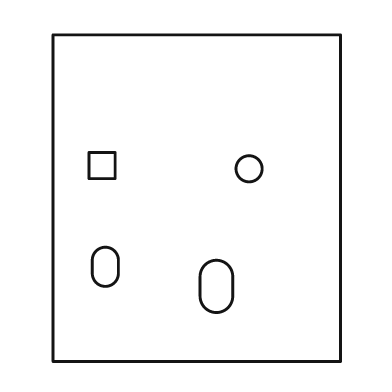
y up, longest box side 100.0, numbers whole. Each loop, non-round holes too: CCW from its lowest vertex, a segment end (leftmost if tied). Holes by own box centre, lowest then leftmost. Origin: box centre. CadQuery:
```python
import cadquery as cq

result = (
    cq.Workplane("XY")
    .moveTo(-44.0, -50.0)
    .lineTo(44.0, -50.0)
    .lineTo(44.0, 50.0)
    .lineTo(-44.0, 50.0)
    .close()
    .moveTo(1.0, -30.0)
    .threePointArc((6.0, -35.0), (11.0, -30.0))
    .lineTo(11.0, -24.0)
    .threePointArc((6.0, -19.0), (1.0, -24.0))
    .close()
    .moveTo(-32.0, -23.0)
    .threePointArc((-28.0, -27.0), (-24.0, -23.0))
    .lineTo(-24.0, -19.0)
    .threePointArc((-28.0, -15.0), (-32.0, -19.0))
    .close()
    .moveTo(16.0, 9.0)
    .circle(4.0)
    .moveTo(-33.0, 6.0)
    .lineTo(-25.0, 6.0)
    .lineTo(-25.0, 14.0)
    .lineTo(-33.0, 14.0)
    .close()
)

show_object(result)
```